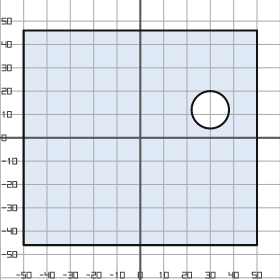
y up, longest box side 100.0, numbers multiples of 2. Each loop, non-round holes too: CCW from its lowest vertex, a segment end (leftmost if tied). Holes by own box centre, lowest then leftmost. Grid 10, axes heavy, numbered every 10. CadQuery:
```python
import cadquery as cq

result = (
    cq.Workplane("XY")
    .moveTo(-50.0, -46.0)
    .lineTo(50.0, -46.0)
    .lineTo(50.0, 46.0)
    .lineTo(-50.0, 46.0)
    .close()
    .moveTo(30.0, 12.0)
    .circle(8.0)
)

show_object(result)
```